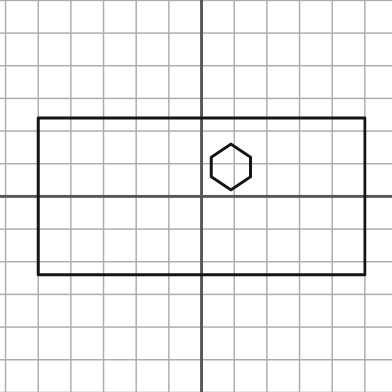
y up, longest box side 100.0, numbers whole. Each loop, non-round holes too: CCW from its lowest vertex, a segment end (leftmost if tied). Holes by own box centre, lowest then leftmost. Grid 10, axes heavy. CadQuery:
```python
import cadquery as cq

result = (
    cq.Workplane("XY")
    .moveTo(-50.0, -24.0)
    .lineTo(50.0, -24.0)
    .lineTo(50.0, 24.0)
    .lineTo(-50.0, 24.0)
    .close()
    .moveTo(9.0, 2.0)
    .lineTo(15.0, 6.0)
    .lineTo(15.0, 12.0)
    .lineTo(9.0, 16.0)
    .lineTo(3.0, 12.0)
    .lineTo(3.0, 6.0)
    .close()
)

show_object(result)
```